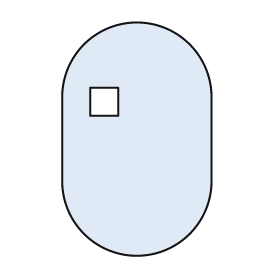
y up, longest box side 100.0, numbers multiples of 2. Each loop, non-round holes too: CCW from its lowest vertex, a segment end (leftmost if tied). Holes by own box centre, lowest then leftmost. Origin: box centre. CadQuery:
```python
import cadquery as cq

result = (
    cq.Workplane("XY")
    .moveTo(-32.0, -18.0)
    .threePointArc((0.0, -50.0), (32.0, -18.0))
    .lineTo(32.0, 18.0)
    .threePointArc((0.0, 50.0), (-32.0, 18.0))
    .close()
    .moveTo(-20.0, 10.0)
    .lineTo(-8.0, 10.0)
    .lineTo(-8.0, 22.0)
    .lineTo(-20.0, 22.0)
    .close()
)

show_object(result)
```